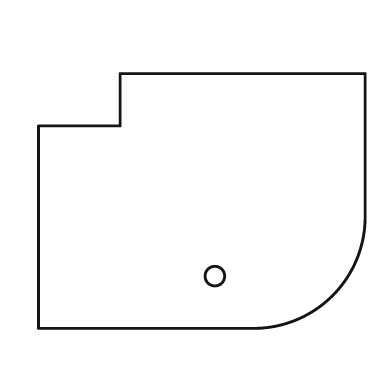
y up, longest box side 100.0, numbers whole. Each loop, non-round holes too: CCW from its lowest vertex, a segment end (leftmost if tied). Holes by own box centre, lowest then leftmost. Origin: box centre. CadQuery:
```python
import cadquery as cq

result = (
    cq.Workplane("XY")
    .moveTo(-50.0, -39.0)
    .lineTo(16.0, -39.0)
    .threePointArc((40.0, -29.0), (50.0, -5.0))
    .lineTo(50.0, 39.0)
    .lineTo(-25.0, 39.0)
    .lineTo(-25.0, 23.0)
    .lineTo(-50.0, 23.0)
    .close()
    .moveTo(4.0, -23.0)
    .circle(3.0)
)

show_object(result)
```